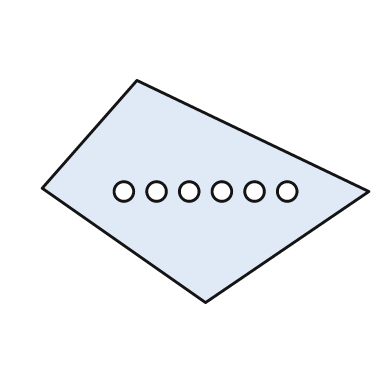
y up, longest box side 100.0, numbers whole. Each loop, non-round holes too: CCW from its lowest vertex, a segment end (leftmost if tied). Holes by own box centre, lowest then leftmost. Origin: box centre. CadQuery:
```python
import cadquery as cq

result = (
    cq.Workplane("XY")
    .moveTo(0.0, -34.0)
    .lineTo(50.0, 0.0)
    .lineTo(-21.0, 34.0)
    .lineTo(-50.0, 1.0)
    .close()
    .moveTo(-25.0, 0.0)
    .circle(3.0)
    .moveTo(-15.0, 0.0)
    .circle(3.0)
    .moveTo(-5.0, 0.0)
    .circle(3.0)
    .moveTo(5.0, 0.0)
    .circle(3.0)
    .moveTo(15.0, 0.0)
    .circle(3.0)
    .moveTo(25.0, 0.0)
    .circle(3.0)
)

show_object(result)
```